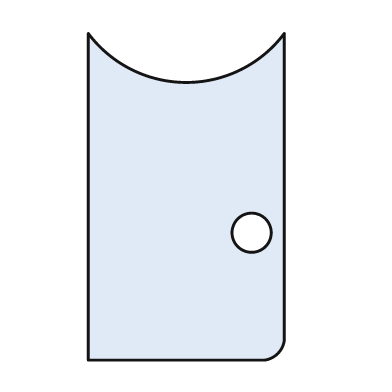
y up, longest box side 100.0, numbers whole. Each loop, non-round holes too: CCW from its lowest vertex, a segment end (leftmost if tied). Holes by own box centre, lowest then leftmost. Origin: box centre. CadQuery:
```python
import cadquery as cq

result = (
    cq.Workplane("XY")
    .moveTo(-30.0, -50.0)
    .lineTo(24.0, -50.0)
    .threePointArc((28.0, -48.0), (30.0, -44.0))
    .lineTo(30.0, 50.0)
    .threePointArc((0.0, 35.0), (-30.0, 50.0))
    .close()
    .moveTo(20.0, -11.0)
    .circle(6.0)
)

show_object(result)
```